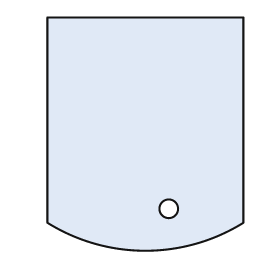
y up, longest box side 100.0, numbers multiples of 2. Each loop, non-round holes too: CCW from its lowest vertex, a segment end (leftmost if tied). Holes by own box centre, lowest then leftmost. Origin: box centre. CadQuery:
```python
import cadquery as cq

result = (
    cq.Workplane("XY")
    .moveTo(-42.0, -38.0)
    .threePointArc((0.0, -50.0), (42.0, -38.0))
    .lineTo(42.0, 50.0)
    .lineTo(-42.0, 50.0)
    .close()
    .moveTo(10.0, -32.0)
    .circle(4.0)
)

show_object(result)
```